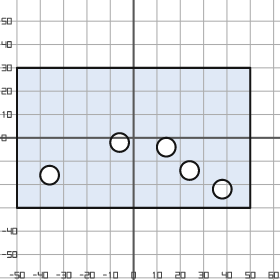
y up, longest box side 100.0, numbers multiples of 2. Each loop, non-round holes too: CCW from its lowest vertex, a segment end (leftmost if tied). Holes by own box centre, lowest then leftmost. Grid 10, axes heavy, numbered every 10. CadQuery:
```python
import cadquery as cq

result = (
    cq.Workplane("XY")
    .moveTo(-50.0, -30.0)
    .lineTo(50.0, -30.0)
    .lineTo(50.0, 30.0)
    .lineTo(-50.0, 30.0)
    .close()
    .moveTo(38.0, -22.0)
    .circle(4.0)
    .moveTo(-36.0, -16.0)
    .circle(4.0)
    .moveTo(24.0, -14.0)
    .circle(4.0)
    .moveTo(14.0, -4.0)
    .circle(4.0)
    .moveTo(-6.0, -2.0)
    .circle(4.0)
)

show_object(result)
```